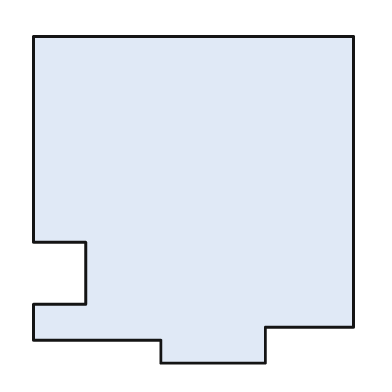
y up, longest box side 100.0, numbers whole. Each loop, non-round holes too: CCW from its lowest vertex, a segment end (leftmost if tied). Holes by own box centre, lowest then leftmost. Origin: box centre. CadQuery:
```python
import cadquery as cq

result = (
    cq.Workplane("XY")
    .moveTo(-10.0, -50.0)
    .lineTo(22.0, -50.0)
    .lineTo(22.0, -39.0)
    .lineTo(49.0, -39.0)
    .lineTo(49.0, 50.0)
    .lineTo(-49.0, 50.0)
    .lineTo(-49.0, -13.0)
    .lineTo(-33.0, -13.0)
    .lineTo(-33.0, -32.0)
    .lineTo(-49.0, -32.0)
    .lineTo(-49.0, -43.0)
    .lineTo(-10.0, -43.0)
    .close()
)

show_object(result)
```